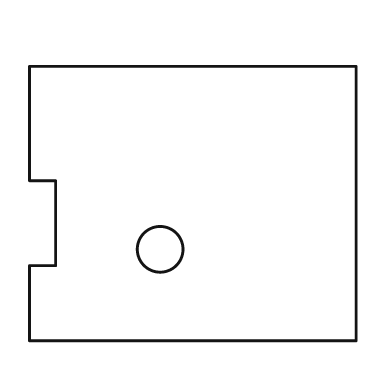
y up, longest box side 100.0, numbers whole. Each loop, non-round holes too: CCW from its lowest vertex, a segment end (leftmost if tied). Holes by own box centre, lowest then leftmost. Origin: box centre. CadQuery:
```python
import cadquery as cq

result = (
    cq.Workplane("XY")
    .moveTo(-50.0, -42.0)
    .lineTo(50.0, -42.0)
    .lineTo(50.0, 42.0)
    .lineTo(-50.0, 42.0)
    .lineTo(-50.0, 7.0)
    .lineTo(-42.0, 7.0)
    .lineTo(-42.0, -19.0)
    .lineTo(-50.0, -19.0)
    .close()
    .moveTo(-10.0, -14.0)
    .circle(7.0)
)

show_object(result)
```